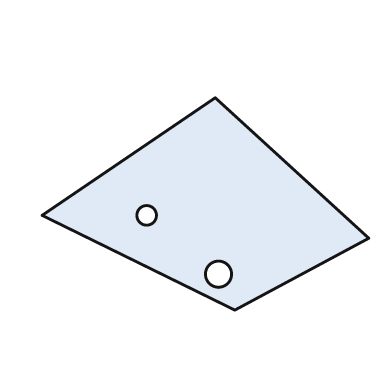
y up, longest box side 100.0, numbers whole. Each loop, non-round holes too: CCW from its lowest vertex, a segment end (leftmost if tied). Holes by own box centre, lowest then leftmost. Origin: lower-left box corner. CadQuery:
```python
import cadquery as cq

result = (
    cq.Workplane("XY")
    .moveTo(59.0, 0.0)
    .lineTo(100.0, 22.0)
    .lineTo(53.0, 65.0)
    .lineTo(0.0, 29.0)
    .close()
    .moveTo(54.0, 11.0)
    .circle(4.0)
    .moveTo(32.0, 29.0)
    .circle(3.0)
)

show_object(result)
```